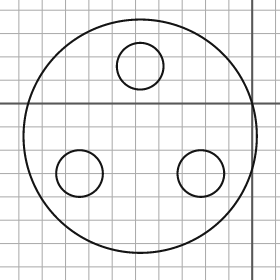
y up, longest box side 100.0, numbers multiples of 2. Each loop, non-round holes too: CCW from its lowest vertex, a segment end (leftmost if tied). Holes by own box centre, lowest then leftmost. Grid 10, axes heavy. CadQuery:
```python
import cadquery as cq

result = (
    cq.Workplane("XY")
    .moveTo(-48.0, -14.0)
    .circle(50.0)
    .moveTo(-74.0, -30.0)
    .circle(10.0)
    .moveTo(-22.0, -30.0)
    .circle(10.0)
    .moveTo(-48.0, 16.0)
    .circle(10.0)
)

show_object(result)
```